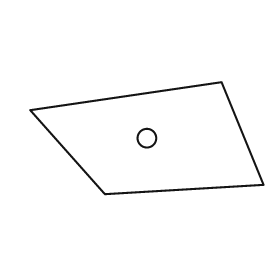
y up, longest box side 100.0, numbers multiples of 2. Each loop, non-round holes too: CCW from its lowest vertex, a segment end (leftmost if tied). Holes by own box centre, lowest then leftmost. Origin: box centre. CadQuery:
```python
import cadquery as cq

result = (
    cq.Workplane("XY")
    .moveTo(-18.0, -24.0)
    .lineTo(50.0, -20.0)
    .lineTo(32.0, 24.0)
    .lineTo(-50.0, 12.0)
    .close()
    .moveTo(0.0, 0.0)
    .circle(4.0)
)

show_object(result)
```